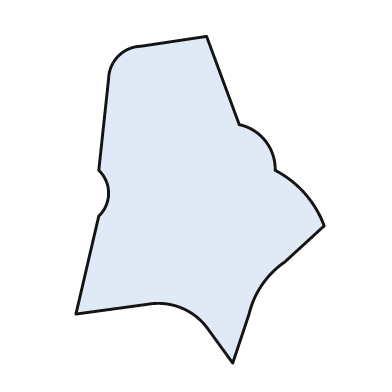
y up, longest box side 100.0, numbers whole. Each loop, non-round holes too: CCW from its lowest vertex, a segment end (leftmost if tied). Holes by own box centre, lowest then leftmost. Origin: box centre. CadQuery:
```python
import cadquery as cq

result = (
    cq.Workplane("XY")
    .moveTo(10.0, -50.0)
    .lineTo(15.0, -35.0)
    .threePointArc((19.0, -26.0), (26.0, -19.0))
    .lineTo(38.0, -8.0)
    .threePointArc((32.0, 2.0), (23.0, 9.0))
    .threePointArc((20.0, 18.0), (12.0, 23.0))
    .lineTo(2.0, 50.0)
    .lineTo(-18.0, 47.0)
    .threePointArc((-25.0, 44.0), (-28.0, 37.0))
    .lineTo(-31.0, 9.0)
    .threePointArc((-28.0, 2.0), (-31.0, -5.0))
    .lineTo(-38.0, -35.0)
    .lineTo(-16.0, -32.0)
    .threePointArc((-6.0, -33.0), (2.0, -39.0))
    .close()
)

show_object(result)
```